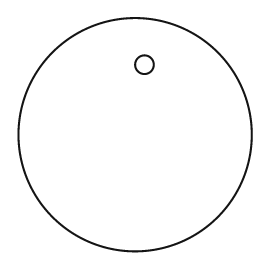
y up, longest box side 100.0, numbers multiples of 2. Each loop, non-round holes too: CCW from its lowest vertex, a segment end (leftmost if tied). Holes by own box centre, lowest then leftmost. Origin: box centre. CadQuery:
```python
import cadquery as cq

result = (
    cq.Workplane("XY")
    .moveTo(0.0, 0.0)
    .circle(50.0)
    .moveTo(4.0, 30.0)
    .circle(4.0)
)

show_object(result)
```